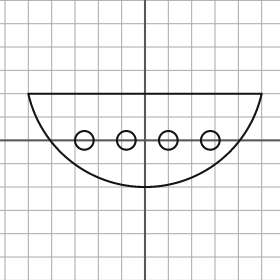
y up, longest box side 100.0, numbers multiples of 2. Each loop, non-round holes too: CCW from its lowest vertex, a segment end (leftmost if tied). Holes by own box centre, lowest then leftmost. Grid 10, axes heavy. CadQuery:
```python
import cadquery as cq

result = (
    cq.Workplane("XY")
    .moveTo(-50.0, 20.0)
    .threePointArc((0.0, -20.0), (50.0, 20.0))
    .close()
    .moveTo(-26.0, 0.0)
    .circle(4.0)
    .moveTo(-8.0, 0.0)
    .circle(4.0)
    .moveTo(10.0, 0.0)
    .circle(4.0)
    .moveTo(28.0, 0.0)
    .circle(4.0)
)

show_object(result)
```